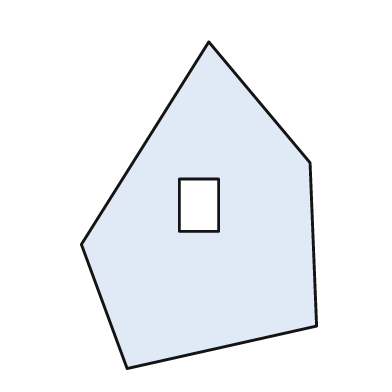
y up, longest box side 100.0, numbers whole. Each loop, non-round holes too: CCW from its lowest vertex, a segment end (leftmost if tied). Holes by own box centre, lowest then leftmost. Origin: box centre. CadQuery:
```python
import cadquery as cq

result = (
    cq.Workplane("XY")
    .moveTo(-22.0, -50.0)
    .lineTo(36.0, -37.0)
    .lineTo(34.0, 13.0)
    .lineTo(3.0, 50.0)
    .lineTo(-36.0, -12.0)
    .close()
    .moveTo(-6.0, -8.0)
    .lineTo(6.0, -8.0)
    .lineTo(6.0, 8.0)
    .lineTo(-6.0, 8.0)
    .close()
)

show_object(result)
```